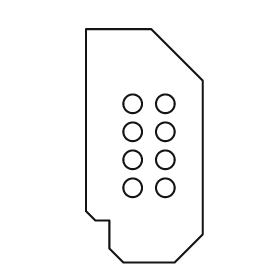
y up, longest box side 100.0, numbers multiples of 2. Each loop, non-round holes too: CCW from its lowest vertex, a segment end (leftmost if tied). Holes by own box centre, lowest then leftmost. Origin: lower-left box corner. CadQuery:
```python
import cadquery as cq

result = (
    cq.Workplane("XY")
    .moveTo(16.0, 0.0)
    .lineTo(38.0, 0.0)
    .lineTo(50.0, 12.0)
    .lineTo(50.0, 78.0)
    .lineTo(28.0, 100.0)
    .lineTo(0.0, 100.0)
    .lineTo(0.0, 22.0)
    .lineTo(4.0, 18.0)
    .lineTo(10.0, 18.0)
    .lineTo(10.0, 6.0)
    .close()
    .moveTo(20.0, 32.0)
    .circle(4.0)
    .moveTo(34.0, 32.0)
    .circle(4.0)
    .moveTo(20.0, 44.0)
    .circle(4.0)
    .moveTo(34.0, 44.0)
    .circle(4.0)
    .moveTo(20.0, 56.0)
    .circle(4.0)
    .moveTo(34.0, 56.0)
    .circle(4.0)
    .moveTo(20.0, 68.0)
    .circle(4.0)
    .moveTo(34.0, 68.0)
    .circle(4.0)
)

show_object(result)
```